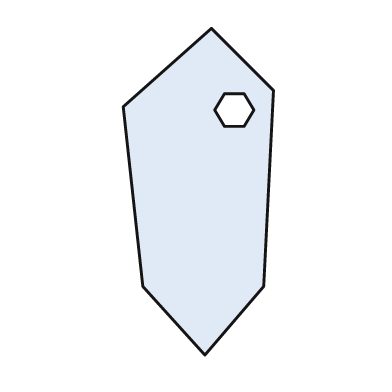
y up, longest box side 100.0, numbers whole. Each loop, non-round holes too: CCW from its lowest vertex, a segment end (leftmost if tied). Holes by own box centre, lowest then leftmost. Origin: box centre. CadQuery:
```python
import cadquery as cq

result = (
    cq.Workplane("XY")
    .moveTo(2.0, -50.0)
    .lineTo(20.0, -29.0)
    .lineTo(23.0, 31.0)
    .lineTo(4.0, 50.0)
    .lineTo(-23.0, 26.0)
    .lineTo(-17.0, -29.0)
    .close()
    .moveTo(8.0, 20.0)
    .lineTo(14.0, 20.0)
    .lineTo(17.0, 25.0)
    .lineTo(14.0, 30.0)
    .lineTo(8.0, 30.0)
    .lineTo(5.0, 25.0)
    .close()
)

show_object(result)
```